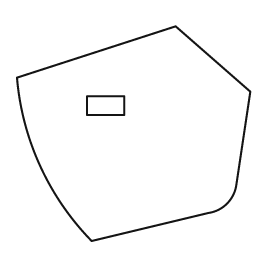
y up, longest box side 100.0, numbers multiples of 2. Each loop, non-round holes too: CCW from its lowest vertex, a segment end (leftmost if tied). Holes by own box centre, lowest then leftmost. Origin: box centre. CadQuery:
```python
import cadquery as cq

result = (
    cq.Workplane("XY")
    .moveTo(-18.0, -46.0)
    .lineTo(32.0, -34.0)
    .threePointArc((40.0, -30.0), (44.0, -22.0))
    .lineTo(50.0, 18.0)
    .lineTo(18.0, 46.0)
    .lineTo(-50.0, 24.0)
    .threePointArc((-40.0, -14.0), (-18.0, -46.0))
    .close()
    .moveTo(-20.0, 8.0)
    .lineTo(-4.0, 8.0)
    .lineTo(-4.0, 16.0)
    .lineTo(-20.0, 16.0)
    .close()
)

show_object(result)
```